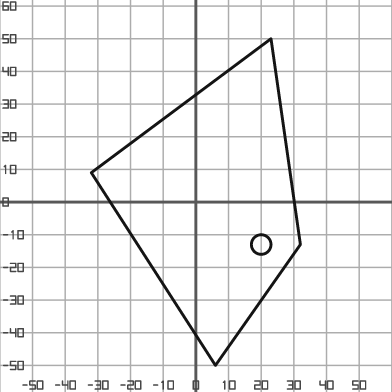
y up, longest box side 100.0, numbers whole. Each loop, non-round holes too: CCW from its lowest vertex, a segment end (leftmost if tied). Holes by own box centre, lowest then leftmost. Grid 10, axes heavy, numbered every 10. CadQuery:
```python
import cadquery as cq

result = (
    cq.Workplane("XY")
    .moveTo(6.0, -50.0)
    .lineTo(32.0, -13.0)
    .lineTo(23.0, 50.0)
    .lineTo(-32.0, 9.0)
    .close()
    .moveTo(20.0, -13.0)
    .circle(3.0)
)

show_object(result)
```